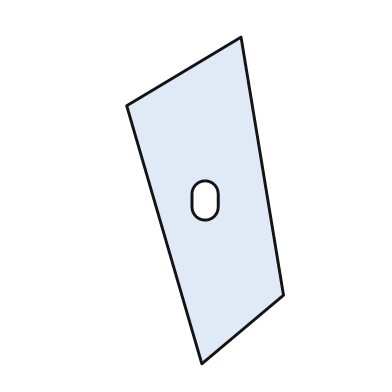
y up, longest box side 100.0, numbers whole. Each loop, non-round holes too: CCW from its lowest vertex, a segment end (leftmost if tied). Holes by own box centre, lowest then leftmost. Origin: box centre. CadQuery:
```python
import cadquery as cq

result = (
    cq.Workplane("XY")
    .moveTo(-1.0, -50.0)
    .lineTo(24.0, -29.0)
    .lineTo(11.0, 50.0)
    .lineTo(-24.0, 29.0)
    .close()
    .moveTo(-4.0, -2.0)
    .threePointArc((0.0, -6.0), (4.0, -2.0))
    .lineTo(4.0, 2.0)
    .threePointArc((0.0, 6.0), (-4.0, 2.0))
    .close()
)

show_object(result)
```